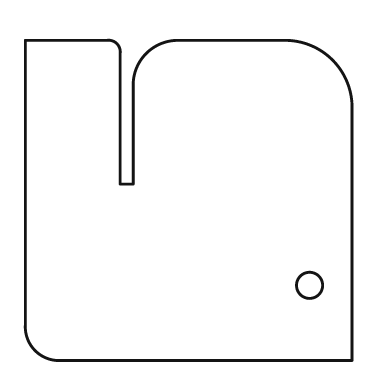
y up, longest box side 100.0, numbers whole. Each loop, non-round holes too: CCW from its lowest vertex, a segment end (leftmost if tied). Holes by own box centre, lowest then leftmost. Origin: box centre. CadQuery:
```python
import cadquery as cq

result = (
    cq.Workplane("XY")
    .moveTo(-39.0, -49.0)
    .lineTo(50.0, -49.0)
    .lineTo(50.0, 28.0)
    .threePointArc((44.0, 43.0), (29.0, 49.0))
    .lineTo(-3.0, 49.0)
    .threePointArc((-13.0, 45.0), (-17.0, 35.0))
    .lineTo(-17.0, 5.0)
    .lineTo(-21.0, 5.0)
    .lineTo(-21.0, 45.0)
    .threePointArc((-22.0, 48.0), (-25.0, 49.0))
    .lineTo(-50.0, 49.0)
    .lineTo(-50.0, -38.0)
    .threePointArc((-47.0, -46.0), (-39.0, -49.0))
    .close()
    .moveTo(37.0, -26.0)
    .circle(4.0)
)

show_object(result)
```